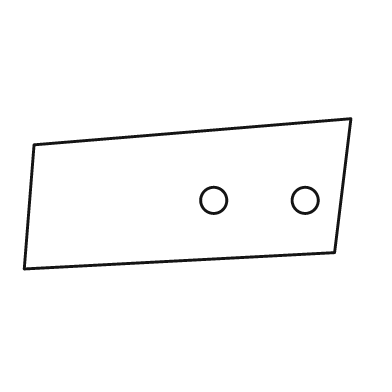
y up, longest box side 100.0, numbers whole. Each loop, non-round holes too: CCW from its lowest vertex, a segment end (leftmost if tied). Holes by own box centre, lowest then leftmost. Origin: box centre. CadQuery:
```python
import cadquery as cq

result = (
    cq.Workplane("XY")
    .moveTo(-50.0, -23.0)
    .lineTo(45.0, -18.0)
    .lineTo(50.0, 23.0)
    .lineTo(-47.0, 15.0)
    .close()
    .moveTo(8.0, -2.0)
    .circle(4.0)
    .moveTo(36.0, -2.0)
    .circle(4.0)
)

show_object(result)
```